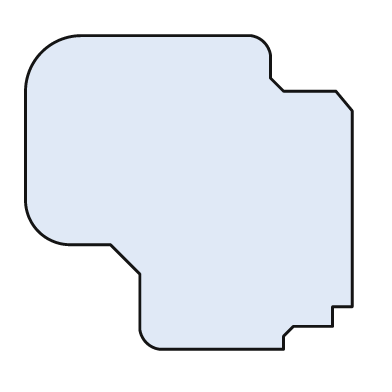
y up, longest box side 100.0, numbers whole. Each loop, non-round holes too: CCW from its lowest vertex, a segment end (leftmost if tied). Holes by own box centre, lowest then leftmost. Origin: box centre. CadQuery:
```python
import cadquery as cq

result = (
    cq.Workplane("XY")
    .moveTo(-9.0, -48.0)
    .lineTo(29.0, -48.0)
    .lineTo(29.0, -44.0)
    .lineTo(32.0, -41.0)
    .lineTo(44.0, -41.0)
    .lineTo(44.0, -35.0)
    .lineTo(50.0, -35.0)
    .lineTo(50.0, 25.0)
    .lineTo(45.0, 31.0)
    .lineTo(29.0, 31.0)
    .lineTo(25.0, 35.0)
    .lineTo(25.0, 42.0)
    .threePointArc((23.0, 46.0), (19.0, 48.0))
    .lineTo(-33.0, 48.0)
    .threePointArc((-45.0, 43.0), (-50.0, 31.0))
    .lineTo(-50.0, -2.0)
    .threePointArc((-46.0, -12.0), (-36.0, -16.0))
    .lineTo(-24.0, -16.0)
    .lineTo(-15.0, -25.0)
    .lineTo(-15.0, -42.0)
    .threePointArc((-13.0, -46.0), (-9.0, -48.0))
    .close()
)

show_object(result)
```